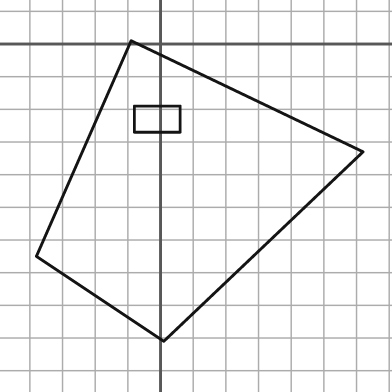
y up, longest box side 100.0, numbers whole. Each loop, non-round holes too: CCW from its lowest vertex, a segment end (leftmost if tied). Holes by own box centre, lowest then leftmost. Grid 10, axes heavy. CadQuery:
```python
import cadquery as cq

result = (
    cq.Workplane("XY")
    .moveTo(1.0, -91.0)
    .lineTo(62.0, -33.0)
    .lineTo(-9.0, 1.0)
    .lineTo(-38.0, -65.0)
    .close()
    .moveTo(-8.0, -27.0)
    .lineTo(6.0, -27.0)
    .lineTo(6.0, -19.0)
    .lineTo(-8.0, -19.0)
    .close()
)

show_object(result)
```